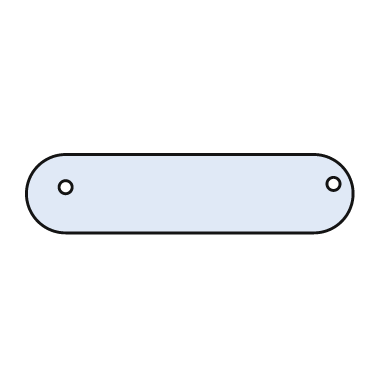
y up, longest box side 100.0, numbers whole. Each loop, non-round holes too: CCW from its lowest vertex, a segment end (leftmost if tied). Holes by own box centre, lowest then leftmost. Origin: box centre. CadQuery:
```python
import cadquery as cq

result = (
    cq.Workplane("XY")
    .moveTo(-38.0, -12.0)
    .lineTo(38.0, -12.0)
    .threePointArc((50.0, 0.0), (38.0, 12.0))
    .lineTo(-38.0, 12.0)
    .threePointArc((-50.0, 0.0), (-38.0, -12.0))
    .close()
    .moveTo(-38.0, 2.0)
    .circle(2.0)
    .moveTo(44.0, 3.0)
    .circle(2.0)
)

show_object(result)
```